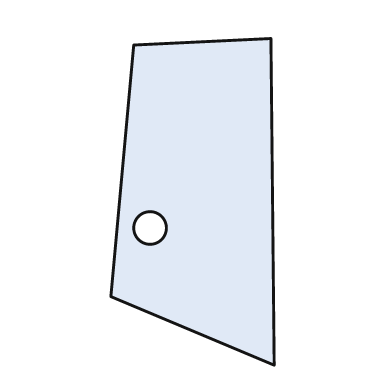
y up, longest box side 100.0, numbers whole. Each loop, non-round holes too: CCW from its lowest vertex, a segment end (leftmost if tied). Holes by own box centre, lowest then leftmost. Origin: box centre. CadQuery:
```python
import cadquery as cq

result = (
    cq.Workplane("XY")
    .moveTo(25.0, -50.0)
    .lineTo(24.0, 50.0)
    .lineTo(-18.0, 48.0)
    .lineTo(-25.0, -29.0)
    .close()
    .moveTo(-13.0, -8.0)
    .circle(5.0)
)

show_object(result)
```